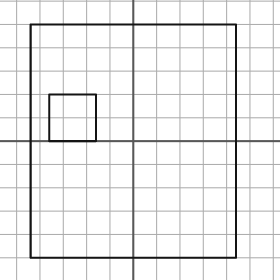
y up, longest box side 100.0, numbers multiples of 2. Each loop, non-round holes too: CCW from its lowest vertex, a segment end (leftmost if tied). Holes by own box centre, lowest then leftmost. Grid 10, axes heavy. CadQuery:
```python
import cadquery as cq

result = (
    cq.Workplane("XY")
    .moveTo(-44.0, -50.0)
    .lineTo(44.0, -50.0)
    .lineTo(44.0, 50.0)
    .lineTo(-44.0, 50.0)
    .close()
    .moveTo(-36.0, 0.0)
    .lineTo(-16.0, 0.0)
    .lineTo(-16.0, 20.0)
    .lineTo(-36.0, 20.0)
    .close()
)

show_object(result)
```